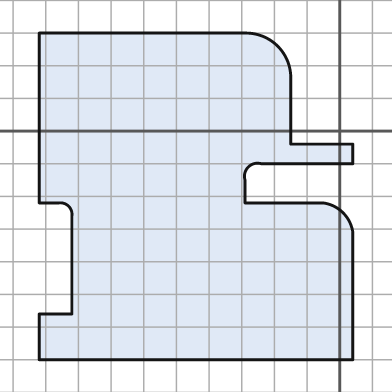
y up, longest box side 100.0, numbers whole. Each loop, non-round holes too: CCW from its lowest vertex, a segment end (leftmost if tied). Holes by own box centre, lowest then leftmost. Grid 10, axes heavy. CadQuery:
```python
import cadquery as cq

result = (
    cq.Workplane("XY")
    .moveTo(-92.0, -70.0)
    .lineTo(4.0, -70.0)
    .lineTo(4.0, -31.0)
    .threePointArc((1.0, -25.0), (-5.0, -22.0))
    .lineTo(-29.0, -22.0)
    .lineTo(-29.0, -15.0)
    .threePointArc((-28.0, -11.0), (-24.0, -10.0))
    .lineTo(4.0, -10.0)
    .lineTo(4.0, -4.0)
    .lineTo(-15.0, -4.0)
    .lineTo(-15.0, 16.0)
    .threePointArc((-19.0, 26.0), (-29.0, 30.0))
    .lineTo(-92.0, 30.0)
    .lineTo(-92.0, -22.0)
    .lineTo(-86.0, -22.0)
    .threePointArc((-83.0, -23.0), (-82.0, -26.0))
    .lineTo(-82.0, -56.0)
    .lineTo(-92.0, -56.0)
    .close()
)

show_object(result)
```